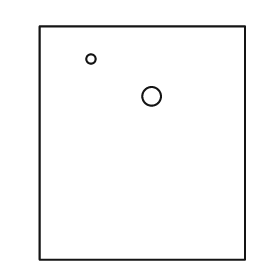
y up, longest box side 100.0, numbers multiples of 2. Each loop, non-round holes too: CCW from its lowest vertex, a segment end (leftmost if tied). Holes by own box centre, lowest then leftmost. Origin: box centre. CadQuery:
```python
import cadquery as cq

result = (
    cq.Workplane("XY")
    .moveTo(-44.0, -50.0)
    .lineTo(44.0, -50.0)
    .lineTo(44.0, 50.0)
    .lineTo(-44.0, 50.0)
    .close()
    .moveTo(4.0, 20.0)
    .circle(4.0)
    .moveTo(-22.0, 36.0)
    .circle(2.0)
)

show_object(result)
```